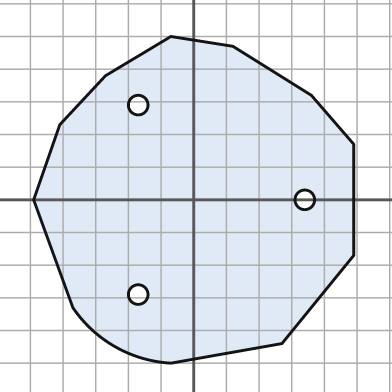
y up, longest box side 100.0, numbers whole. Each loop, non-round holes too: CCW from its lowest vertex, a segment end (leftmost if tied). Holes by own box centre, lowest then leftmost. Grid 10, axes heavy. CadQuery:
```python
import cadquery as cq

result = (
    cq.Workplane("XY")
    .moveTo(-7.0, -50.0)
    .lineTo(27.0, -44.0)
    .lineTo(49.0, -17.0)
    .lineTo(49.0, 17.0)
    .lineTo(36.0, 32.0)
    .lineTo(12.0, 47.0)
    .lineTo(-7.0, 50.0)
    .lineTo(-27.0, 38.0)
    .lineTo(-41.0, 23.0)
    .lineTo(-49.0, 0.0)
    .lineTo(-37.0, -33.0)
    .threePointArc((-24.0, -45.0), (-7.0, -50.0))
    .close()
    .moveTo(-17.0, -29.0)
    .circle(3.0)
    .moveTo(34.0, 0.0)
    .circle(3.0)
    .moveTo(-17.0, 29.0)
    .circle(3.0)
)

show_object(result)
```